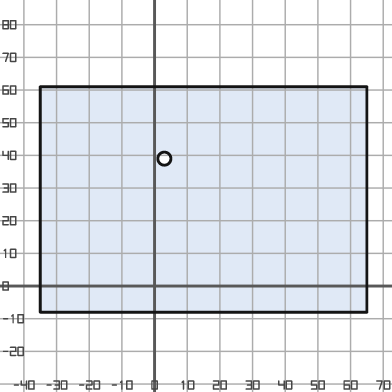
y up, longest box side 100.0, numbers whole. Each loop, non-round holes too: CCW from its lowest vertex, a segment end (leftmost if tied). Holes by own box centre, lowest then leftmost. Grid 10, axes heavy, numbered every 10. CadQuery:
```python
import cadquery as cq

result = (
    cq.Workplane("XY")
    .moveTo(-35.0, -8.0)
    .lineTo(65.0, -8.0)
    .lineTo(65.0, 61.0)
    .lineTo(-35.0, 61.0)
    .close()
    .moveTo(3.0, 39.0)
    .circle(2.0)
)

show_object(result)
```